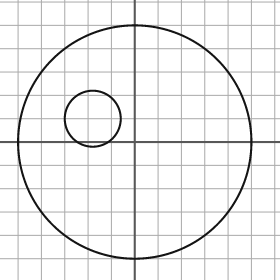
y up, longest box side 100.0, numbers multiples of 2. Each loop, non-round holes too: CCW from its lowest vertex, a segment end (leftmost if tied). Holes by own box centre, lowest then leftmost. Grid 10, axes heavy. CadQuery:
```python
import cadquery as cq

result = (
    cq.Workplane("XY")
    .moveTo(0.0, 0.0)
    .circle(50.0)
    .moveTo(-18.0, 10.0)
    .circle(12.0)
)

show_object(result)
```